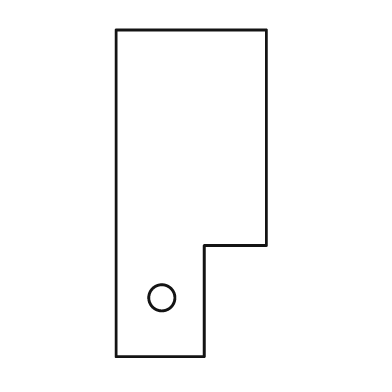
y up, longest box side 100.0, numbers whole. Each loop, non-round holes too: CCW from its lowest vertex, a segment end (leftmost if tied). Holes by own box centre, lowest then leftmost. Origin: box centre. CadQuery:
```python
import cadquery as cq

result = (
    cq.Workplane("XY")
    .moveTo(-23.0, -50.0)
    .lineTo(4.0, -50.0)
    .lineTo(4.0, -16.0)
    .lineTo(23.0, -16.0)
    .lineTo(23.0, 50.0)
    .lineTo(-23.0, 50.0)
    .close()
    .moveTo(-9.0, -32.0)
    .circle(4.0)
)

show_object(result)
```